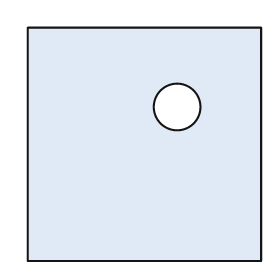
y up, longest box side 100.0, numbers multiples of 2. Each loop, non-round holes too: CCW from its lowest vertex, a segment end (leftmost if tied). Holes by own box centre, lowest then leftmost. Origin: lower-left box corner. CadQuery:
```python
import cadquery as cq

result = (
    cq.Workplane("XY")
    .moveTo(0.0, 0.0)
    .lineTo(100.0, 0.0)
    .lineTo(100.0, 100.0)
    .lineTo(0.0, 100.0)
    .close()
    .moveTo(64.0, 66.0)
    .circle(10.0)
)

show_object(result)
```